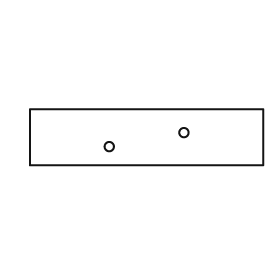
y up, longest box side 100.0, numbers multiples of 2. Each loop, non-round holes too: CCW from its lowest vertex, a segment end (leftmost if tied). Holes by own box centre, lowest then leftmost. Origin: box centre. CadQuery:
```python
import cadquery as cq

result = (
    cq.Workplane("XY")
    .moveTo(-50.0, -12.0)
    .lineTo(50.0, -12.0)
    .lineTo(50.0, 12.0)
    .lineTo(-50.0, 12.0)
    .close()
    .moveTo(-16.0, -4.0)
    .circle(2.0)
    .moveTo(16.0, 2.0)
    .circle(2.0)
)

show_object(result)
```